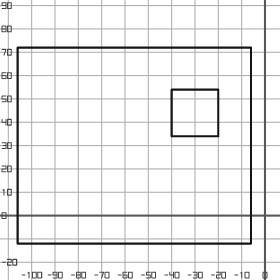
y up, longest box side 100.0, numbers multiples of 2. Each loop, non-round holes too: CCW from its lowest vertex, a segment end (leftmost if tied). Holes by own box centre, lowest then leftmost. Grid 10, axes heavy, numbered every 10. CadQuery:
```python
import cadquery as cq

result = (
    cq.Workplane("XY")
    .moveTo(-106.0, -12.0)
    .lineTo(-6.0, -12.0)
    .lineTo(-6.0, 72.0)
    .lineTo(-106.0, 72.0)
    .close()
    .moveTo(-40.0, 34.0)
    .lineTo(-20.0, 34.0)
    .lineTo(-20.0, 54.0)
    .lineTo(-40.0, 54.0)
    .close()
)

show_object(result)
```